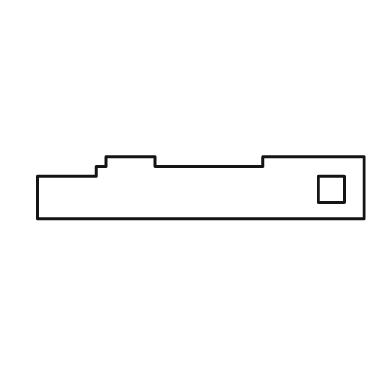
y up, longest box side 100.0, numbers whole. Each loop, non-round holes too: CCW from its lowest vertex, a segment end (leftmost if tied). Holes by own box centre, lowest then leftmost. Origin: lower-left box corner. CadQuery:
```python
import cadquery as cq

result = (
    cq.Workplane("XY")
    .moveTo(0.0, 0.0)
    .lineTo(100.0, 0.0)
    .lineTo(100.0, 19.0)
    .lineTo(69.0, 19.0)
    .lineTo(69.0, 16.0)
    .lineTo(36.0, 16.0)
    .lineTo(36.0, 19.0)
    .lineTo(21.0, 19.0)
    .lineTo(21.0, 16.0)
    .lineTo(18.0, 16.0)
    .lineTo(18.0, 13.0)
    .lineTo(0.0, 13.0)
    .close()
    .moveTo(86.0, 5.0)
    .lineTo(94.0, 5.0)
    .lineTo(94.0, 13.0)
    .lineTo(86.0, 13.0)
    .close()
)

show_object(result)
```